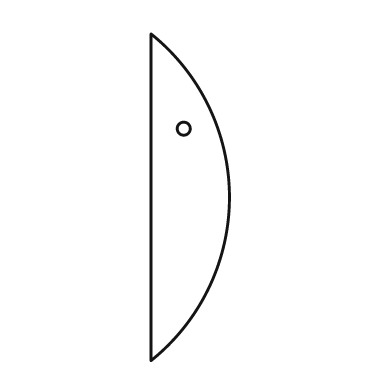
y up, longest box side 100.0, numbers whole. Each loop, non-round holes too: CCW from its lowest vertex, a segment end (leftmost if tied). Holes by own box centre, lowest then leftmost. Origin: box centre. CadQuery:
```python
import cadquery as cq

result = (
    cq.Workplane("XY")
    .moveTo(-12.0, -50.0)
    .threePointArc((12.0, 0.0), (-12.0, 50.0))
    .close()
    .moveTo(-2.0, 21.0)
    .circle(2.0)
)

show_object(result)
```